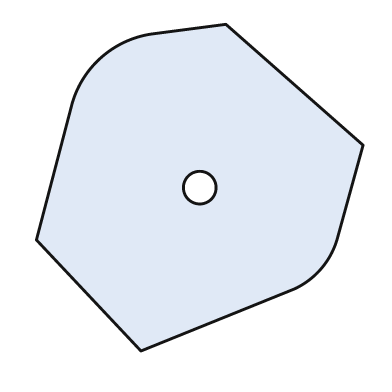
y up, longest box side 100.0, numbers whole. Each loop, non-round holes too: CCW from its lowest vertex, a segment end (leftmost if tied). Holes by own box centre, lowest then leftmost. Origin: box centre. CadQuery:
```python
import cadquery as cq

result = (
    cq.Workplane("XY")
    .moveTo(-18.0, -50.0)
    .lineTo(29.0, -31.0)
    .threePointArc((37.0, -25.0), (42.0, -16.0))
    .lineTo(50.0, 13.0)
    .lineTo(8.0, 50.0)
    .lineTo(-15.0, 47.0)
    .threePointArc((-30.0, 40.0), (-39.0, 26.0))
    .lineTo(-50.0, -16.0)
    .close()
    .moveTo(0.0, 0.0)
    .circle(5.0)
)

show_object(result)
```